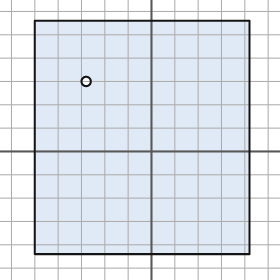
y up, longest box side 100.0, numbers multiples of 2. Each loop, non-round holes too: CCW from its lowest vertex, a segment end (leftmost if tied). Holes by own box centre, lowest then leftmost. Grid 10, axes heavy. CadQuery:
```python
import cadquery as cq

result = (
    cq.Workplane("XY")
    .moveTo(-50.0, -44.0)
    .lineTo(42.0, -44.0)
    .lineTo(42.0, 56.0)
    .lineTo(-50.0, 56.0)
    .close()
    .moveTo(-28.0, 30.0)
    .circle(2.0)
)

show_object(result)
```